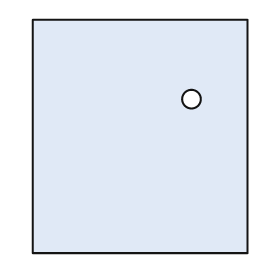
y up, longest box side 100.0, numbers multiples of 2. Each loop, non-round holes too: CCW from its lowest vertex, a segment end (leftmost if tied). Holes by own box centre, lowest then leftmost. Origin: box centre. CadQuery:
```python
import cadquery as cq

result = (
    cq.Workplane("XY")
    .moveTo(-46.0, -50.0)
    .lineTo(46.0, -50.0)
    .lineTo(46.0, 50.0)
    .lineTo(-46.0, 50.0)
    .close()
    .moveTo(22.0, 16.0)
    .circle(4.0)
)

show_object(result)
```